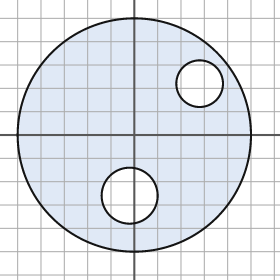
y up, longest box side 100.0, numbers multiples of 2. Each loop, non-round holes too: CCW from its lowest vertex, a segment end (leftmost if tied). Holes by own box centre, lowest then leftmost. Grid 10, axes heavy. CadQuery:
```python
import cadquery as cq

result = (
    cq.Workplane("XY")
    .moveTo(0.0, 0.0)
    .circle(50.0)
    .moveTo(-2.0, -26.0)
    .circle(12.0)
    .moveTo(28.0, 22.0)
    .circle(10.0)
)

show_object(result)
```